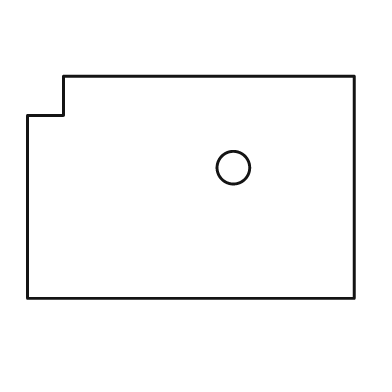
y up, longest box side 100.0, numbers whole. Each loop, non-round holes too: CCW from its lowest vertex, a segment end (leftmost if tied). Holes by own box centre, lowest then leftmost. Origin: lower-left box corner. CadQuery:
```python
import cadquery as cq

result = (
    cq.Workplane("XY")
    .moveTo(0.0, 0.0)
    .lineTo(100.0, 0.0)
    .lineTo(100.0, 68.0)
    .lineTo(11.0, 68.0)
    .lineTo(11.0, 56.0)
    .lineTo(0.0, 56.0)
    .close()
    .moveTo(63.0, 40.0)
    .circle(5.0)
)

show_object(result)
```